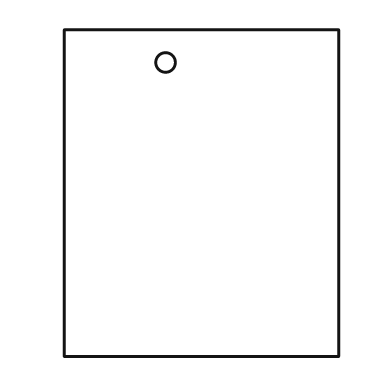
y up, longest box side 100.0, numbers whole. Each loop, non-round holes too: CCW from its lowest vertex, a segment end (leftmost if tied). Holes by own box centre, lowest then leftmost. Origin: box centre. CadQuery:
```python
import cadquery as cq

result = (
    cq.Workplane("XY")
    .moveTo(-42.0, -50.0)
    .lineTo(42.0, -50.0)
    .lineTo(42.0, 50.0)
    .lineTo(-42.0, 50.0)
    .close()
    .moveTo(-11.0, 40.0)
    .circle(3.0)
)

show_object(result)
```